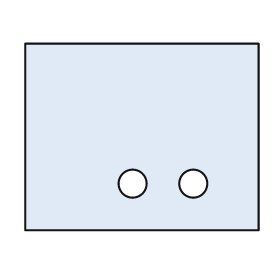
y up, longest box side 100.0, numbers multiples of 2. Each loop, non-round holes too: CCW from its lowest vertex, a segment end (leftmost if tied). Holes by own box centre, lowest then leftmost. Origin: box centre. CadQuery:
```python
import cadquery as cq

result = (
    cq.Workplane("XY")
    .moveTo(-50.0, -40.0)
    .lineTo(50.0, -40.0)
    .lineTo(50.0, 40.0)
    .lineTo(-50.0, 40.0)
    .close()
    .moveTo(-4.0, -20.0)
    .circle(6.0)
    .moveTo(22.0, -20.0)
    .circle(6.0)
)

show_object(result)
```